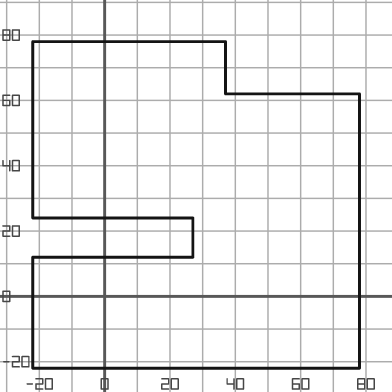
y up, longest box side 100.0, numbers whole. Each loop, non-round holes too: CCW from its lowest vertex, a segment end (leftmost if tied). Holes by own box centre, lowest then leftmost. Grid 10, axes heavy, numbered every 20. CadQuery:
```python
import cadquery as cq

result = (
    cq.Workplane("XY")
    .moveTo(-22.0, -22.0)
    .lineTo(78.0, -22.0)
    .lineTo(78.0, 62.0)
    .lineTo(37.0, 62.0)
    .lineTo(37.0, 78.0)
    .lineTo(-22.0, 78.0)
    .lineTo(-22.0, 24.0)
    .lineTo(27.0, 24.0)
    .lineTo(27.0, 12.0)
    .lineTo(-22.0, 12.0)
    .close()
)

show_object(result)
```